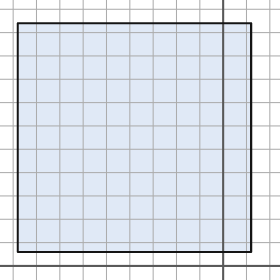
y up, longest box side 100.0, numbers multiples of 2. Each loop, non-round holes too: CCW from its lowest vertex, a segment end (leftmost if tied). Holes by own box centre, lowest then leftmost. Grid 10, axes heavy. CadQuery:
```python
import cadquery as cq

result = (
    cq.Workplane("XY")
    .moveTo(-88.0, 6.0)
    .lineTo(12.0, 6.0)
    .lineTo(12.0, 104.0)
    .lineTo(-88.0, 104.0)
    .close()
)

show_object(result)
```